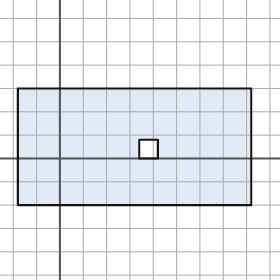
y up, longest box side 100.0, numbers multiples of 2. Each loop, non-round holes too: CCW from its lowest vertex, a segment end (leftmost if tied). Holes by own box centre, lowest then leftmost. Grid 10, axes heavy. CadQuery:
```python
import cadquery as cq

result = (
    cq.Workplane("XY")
    .moveTo(-18.0, -20.0)
    .lineTo(82.0, -20.0)
    .lineTo(82.0, 30.0)
    .lineTo(-18.0, 30.0)
    .close()
    .moveTo(34.0, 0.0)
    .lineTo(42.0, 0.0)
    .lineTo(42.0, 8.0)
    .lineTo(34.0, 8.0)
    .close()
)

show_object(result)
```